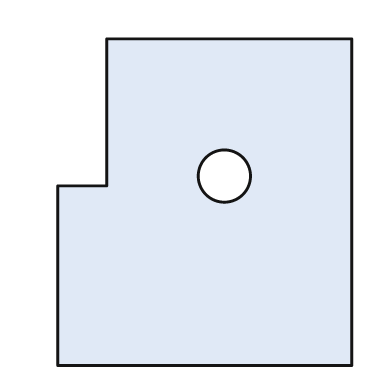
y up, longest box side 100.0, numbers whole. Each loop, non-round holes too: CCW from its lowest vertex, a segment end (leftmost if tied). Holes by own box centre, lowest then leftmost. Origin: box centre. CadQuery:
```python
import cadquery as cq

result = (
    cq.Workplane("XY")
    .moveTo(-45.0, -50.0)
    .lineTo(45.0, -50.0)
    .lineTo(45.0, 50.0)
    .lineTo(-30.0, 50.0)
    .lineTo(-30.0, 5.0)
    .lineTo(-45.0, 5.0)
    .close()
    .moveTo(6.0, 8.0)
    .circle(8.0)
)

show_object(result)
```